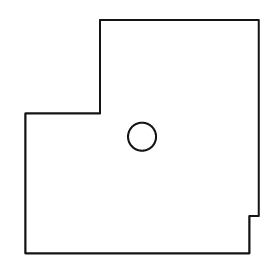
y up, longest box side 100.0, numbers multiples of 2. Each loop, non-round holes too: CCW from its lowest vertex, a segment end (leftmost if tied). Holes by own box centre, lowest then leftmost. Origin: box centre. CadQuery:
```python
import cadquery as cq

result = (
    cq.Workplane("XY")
    .moveTo(-50.0, -50.0)
    .lineTo(46.0, -50.0)
    .lineTo(46.0, -34.0)
    .lineTo(50.0, -34.0)
    .lineTo(50.0, 50.0)
    .lineTo(-18.0, 50.0)
    .lineTo(-18.0, 10.0)
    .lineTo(-50.0, 10.0)
    .close()
    .moveTo(0.0, 0.0)
    .circle(6.0)
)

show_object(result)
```